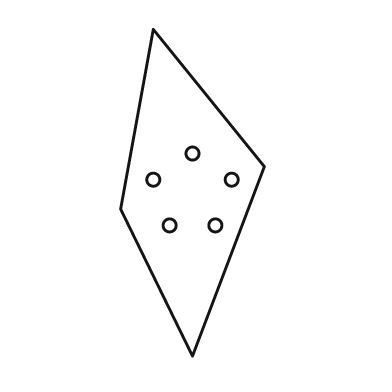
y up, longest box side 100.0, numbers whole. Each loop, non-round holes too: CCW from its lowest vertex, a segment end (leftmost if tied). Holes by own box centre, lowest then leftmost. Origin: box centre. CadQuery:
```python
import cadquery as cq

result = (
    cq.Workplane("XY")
    .moveTo(0.0, -50.0)
    .lineTo(22.0, 8.0)
    .lineTo(-12.0, 50.0)
    .lineTo(-22.0, -5.0)
    .close()
    .moveTo(-7.0, -10.0)
    .circle(2.0)
    .moveTo(7.0, -10.0)
    .circle(2.0)
    .moveTo(-12.0, 4.0)
    .circle(2.0)
    .moveTo(12.0, 4.0)
    .circle(2.0)
    .moveTo(0.0, 12.0)
    .circle(2.0)
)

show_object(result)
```